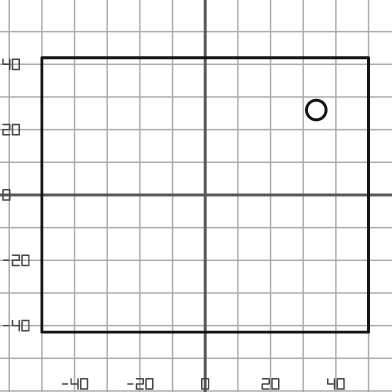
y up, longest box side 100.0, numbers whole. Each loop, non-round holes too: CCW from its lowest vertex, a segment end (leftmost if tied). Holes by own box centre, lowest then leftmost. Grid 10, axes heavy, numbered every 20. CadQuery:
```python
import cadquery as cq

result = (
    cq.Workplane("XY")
    .moveTo(-50.0, -42.0)
    .lineTo(50.0, -42.0)
    .lineTo(50.0, 42.0)
    .lineTo(-50.0, 42.0)
    .close()
    .moveTo(34.0, 26.0)
    .circle(3.0)
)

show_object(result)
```